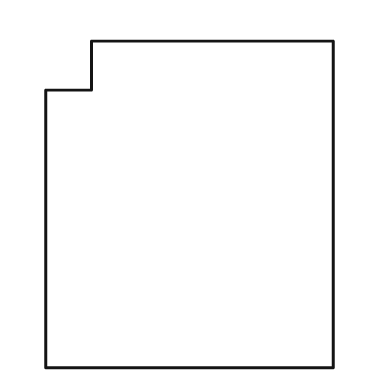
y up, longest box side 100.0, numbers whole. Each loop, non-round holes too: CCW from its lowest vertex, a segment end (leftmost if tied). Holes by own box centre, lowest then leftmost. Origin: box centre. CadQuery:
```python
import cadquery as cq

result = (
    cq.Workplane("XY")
    .moveTo(-44.0, -50.0)
    .lineTo(44.0, -50.0)
    .lineTo(44.0, 50.0)
    .lineTo(-30.0, 50.0)
    .lineTo(-30.0, 35.0)
    .lineTo(-44.0, 35.0)
    .close()
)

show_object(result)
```